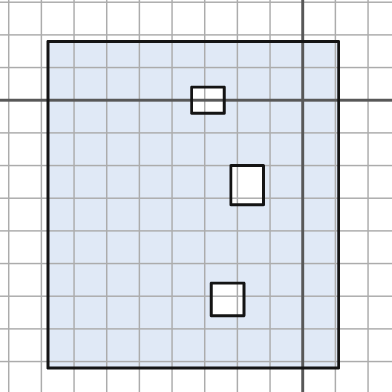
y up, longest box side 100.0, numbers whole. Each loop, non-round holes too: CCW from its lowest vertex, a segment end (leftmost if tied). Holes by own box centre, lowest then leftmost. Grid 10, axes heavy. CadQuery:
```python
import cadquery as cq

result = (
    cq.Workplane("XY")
    .moveTo(-78.0, -82.0)
    .lineTo(11.0, -82.0)
    .lineTo(11.0, 18.0)
    .lineTo(-78.0, 18.0)
    .close()
    .moveTo(-28.0, -66.0)
    .lineTo(-18.0, -66.0)
    .lineTo(-18.0, -56.0)
    .lineTo(-28.0, -56.0)
    .close()
    .moveTo(-22.0, -32.0)
    .lineTo(-12.0, -32.0)
    .lineTo(-12.0, -20.0)
    .lineTo(-22.0, -20.0)
    .close()
    .moveTo(-34.0, -4.0)
    .lineTo(-24.0, -4.0)
    .lineTo(-24.0, 4.0)
    .lineTo(-34.0, 4.0)
    .close()
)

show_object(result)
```